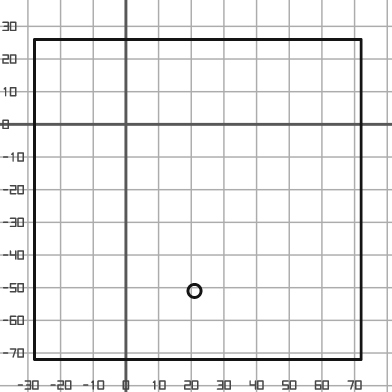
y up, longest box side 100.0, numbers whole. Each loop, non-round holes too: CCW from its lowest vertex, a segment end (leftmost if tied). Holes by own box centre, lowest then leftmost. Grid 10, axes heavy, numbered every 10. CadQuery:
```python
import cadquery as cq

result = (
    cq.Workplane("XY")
    .moveTo(-28.0, -72.0)
    .lineTo(72.0, -72.0)
    .lineTo(72.0, 26.0)
    .lineTo(-28.0, 26.0)
    .close()
    .moveTo(21.0, -51.0)
    .circle(2.0)
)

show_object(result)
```